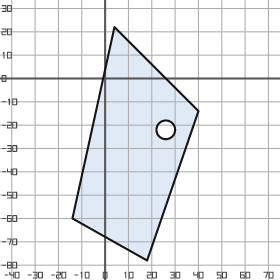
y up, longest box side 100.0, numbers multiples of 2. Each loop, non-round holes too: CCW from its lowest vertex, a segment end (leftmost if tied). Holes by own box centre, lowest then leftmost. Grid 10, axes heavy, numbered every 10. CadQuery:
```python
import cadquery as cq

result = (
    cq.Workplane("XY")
    .moveTo(18.0, -78.0)
    .lineTo(40.0, -14.0)
    .lineTo(4.0, 22.0)
    .lineTo(-14.0, -60.0)
    .close()
    .moveTo(26.0, -22.0)
    .circle(4.0)
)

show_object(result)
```